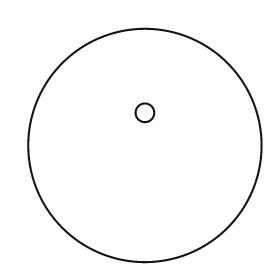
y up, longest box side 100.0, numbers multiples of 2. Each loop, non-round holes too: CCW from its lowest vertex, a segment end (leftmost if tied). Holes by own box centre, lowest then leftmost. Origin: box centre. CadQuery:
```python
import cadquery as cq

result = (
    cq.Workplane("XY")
    .moveTo(0.0, 0.0)
    .circle(50.0)
    .moveTo(0.0, 14.0)
    .circle(4.0)
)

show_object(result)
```